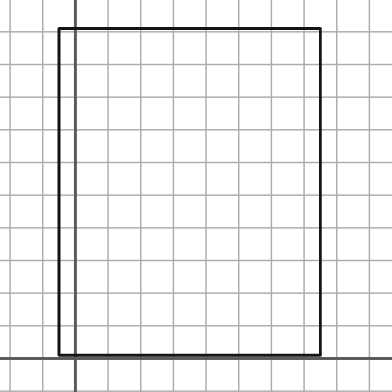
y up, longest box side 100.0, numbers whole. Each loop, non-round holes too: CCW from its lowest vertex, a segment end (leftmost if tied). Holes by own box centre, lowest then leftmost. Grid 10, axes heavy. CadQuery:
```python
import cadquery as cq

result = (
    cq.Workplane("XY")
    .moveTo(-5.0, 1.0)
    .lineTo(75.0, 1.0)
    .lineTo(75.0, 101.0)
    .lineTo(-5.0, 101.0)
    .close()
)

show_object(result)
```